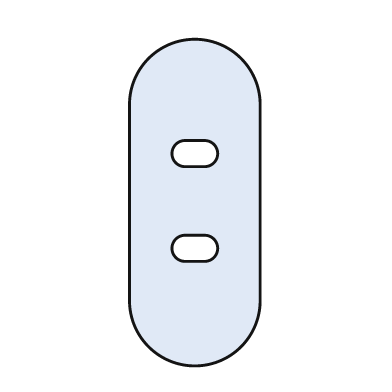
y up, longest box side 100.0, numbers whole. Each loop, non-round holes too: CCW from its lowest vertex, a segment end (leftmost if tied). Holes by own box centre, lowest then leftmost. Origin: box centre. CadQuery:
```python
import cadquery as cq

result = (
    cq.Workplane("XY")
    .moveTo(-20.0, -30.0)
    .threePointArc((0.0, -50.0), (20.0, -30.0))
    .lineTo(20.0, 30.0)
    .threePointArc((0.0, 50.0), (-20.0, 30.0))
    .close()
    .moveTo(-3.0, -18.0)
    .lineTo(3.0, -18.0)
    .threePointArc((7.0, -14.0), (3.0, -10.0))
    .lineTo(-3.0, -10.0)
    .threePointArc((-7.0, -14.0), (-3.0, -18.0))
    .close()
    .moveTo(-3.0, 11.0)
    .lineTo(3.0, 11.0)
    .threePointArc((7.0, 15.0), (3.0, 19.0))
    .lineTo(-3.0, 19.0)
    .threePointArc((-7.0, 15.0), (-3.0, 11.0))
    .close()
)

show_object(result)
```